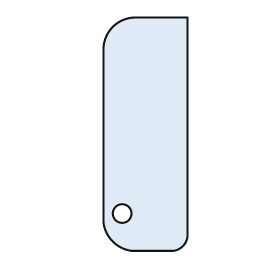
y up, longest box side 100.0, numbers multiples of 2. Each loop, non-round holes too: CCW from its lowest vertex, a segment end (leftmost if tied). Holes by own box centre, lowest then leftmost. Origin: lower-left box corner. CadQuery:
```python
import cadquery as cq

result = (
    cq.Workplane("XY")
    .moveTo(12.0, 0.0)
    .lineTo(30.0, 0.0)
    .threePointArc((34.0, 2.0), (36.0, 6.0))
    .lineTo(36.0, 100.0)
    .lineTo(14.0, 100.0)
    .threePointArc((4.0, 96.0), (0.0, 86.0))
    .lineTo(0.0, 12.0)
    .threePointArc((4.0, 4.0), (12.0, 0.0))
    .close()
    .moveTo(8.0, 16.0)
    .circle(4.0)
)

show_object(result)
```